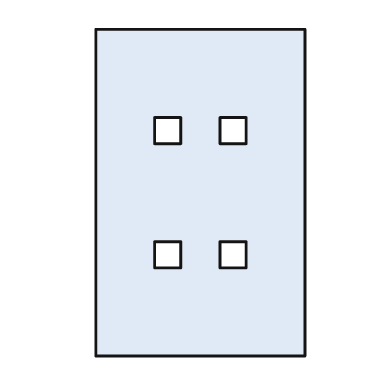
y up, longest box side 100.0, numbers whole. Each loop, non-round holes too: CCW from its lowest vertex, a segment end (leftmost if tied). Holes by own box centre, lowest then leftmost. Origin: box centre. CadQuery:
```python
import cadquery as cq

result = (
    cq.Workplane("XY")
    .moveTo(-32.0, -50.0)
    .lineTo(32.0, -50.0)
    .lineTo(32.0, 50.0)
    .lineTo(-32.0, 50.0)
    .close()
    .moveTo(-14.0, -23.0)
    .lineTo(-6.0, -23.0)
    .lineTo(-6.0, -15.0)
    .lineTo(-14.0, -15.0)
    .close()
    .moveTo(6.0, -23.0)
    .lineTo(14.0, -23.0)
    .lineTo(14.0, -15.0)
    .lineTo(6.0, -15.0)
    .close()
    .moveTo(-14.0, 15.0)
    .lineTo(-6.0, 15.0)
    .lineTo(-6.0, 23.0)
    .lineTo(-14.0, 23.0)
    .close()
    .moveTo(6.0, 15.0)
    .lineTo(14.0, 15.0)
    .lineTo(14.0, 23.0)
    .lineTo(6.0, 23.0)
    .close()
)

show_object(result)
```